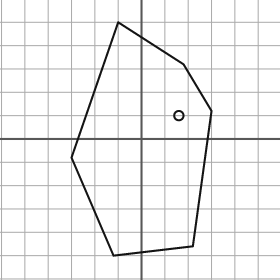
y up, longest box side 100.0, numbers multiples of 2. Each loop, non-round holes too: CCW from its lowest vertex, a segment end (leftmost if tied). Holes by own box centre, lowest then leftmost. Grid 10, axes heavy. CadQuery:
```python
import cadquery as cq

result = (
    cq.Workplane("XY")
    .moveTo(-12.0, -50.0)
    .lineTo(22.0, -46.0)
    .lineTo(30.0, 12.0)
    .lineTo(18.0, 32.0)
    .lineTo(-10.0, 50.0)
    .lineTo(-30.0, -8.0)
    .close()
    .moveTo(16.0, 10.0)
    .circle(2.0)
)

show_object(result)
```